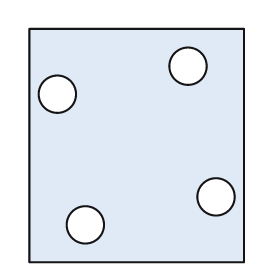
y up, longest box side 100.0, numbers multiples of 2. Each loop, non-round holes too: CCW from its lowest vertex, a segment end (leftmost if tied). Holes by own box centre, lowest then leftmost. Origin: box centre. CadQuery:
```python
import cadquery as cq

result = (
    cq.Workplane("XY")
    .moveTo(-46.0, -50.0)
    .lineTo(46.0, -50.0)
    .lineTo(46.0, 50.0)
    .lineTo(-46.0, 50.0)
    .close()
    .moveTo(-22.0, -34.0)
    .circle(8.0)
    .moveTo(34.0, -22.0)
    .circle(8.0)
    .moveTo(-34.0, 22.0)
    .circle(8.0)
    .moveTo(22.0, 34.0)
    .circle(8.0)
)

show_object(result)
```